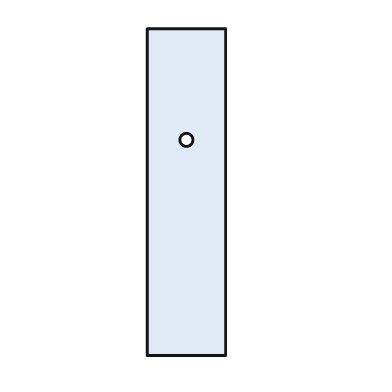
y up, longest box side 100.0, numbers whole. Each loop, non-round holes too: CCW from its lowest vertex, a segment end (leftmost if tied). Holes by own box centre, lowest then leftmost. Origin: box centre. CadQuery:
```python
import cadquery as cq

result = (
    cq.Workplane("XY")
    .moveTo(-12.0, -50.0)
    .lineTo(12.0, -50.0)
    .lineTo(12.0, 50.0)
    .lineTo(-12.0, 50.0)
    .close()
    .moveTo(0.0, 16.0)
    .circle(2.0)
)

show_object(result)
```